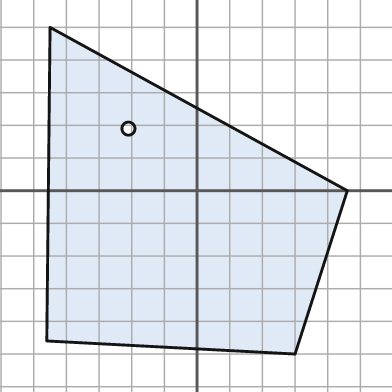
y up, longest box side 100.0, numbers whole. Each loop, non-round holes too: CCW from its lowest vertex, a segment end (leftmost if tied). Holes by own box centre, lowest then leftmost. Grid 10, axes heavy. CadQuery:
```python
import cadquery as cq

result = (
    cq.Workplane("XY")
    .moveTo(30.0, -50.0)
    .lineTo(46.0, 0.0)
    .lineTo(-45.0, 50.0)
    .lineTo(-46.0, -46.0)
    .close()
    .moveTo(-21.0, 19.0)
    .circle(2.0)
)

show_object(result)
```